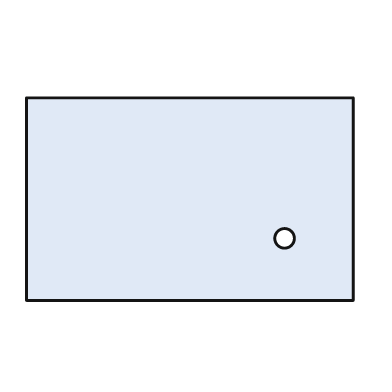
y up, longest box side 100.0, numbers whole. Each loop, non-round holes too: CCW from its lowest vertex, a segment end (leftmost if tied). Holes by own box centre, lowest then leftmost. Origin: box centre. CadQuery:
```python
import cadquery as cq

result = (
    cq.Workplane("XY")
    .moveTo(-50.0, -31.0)
    .lineTo(50.0, -31.0)
    .lineTo(50.0, 31.0)
    .lineTo(-50.0, 31.0)
    .close()
    .moveTo(29.0, -12.0)
    .circle(3.0)
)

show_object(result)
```